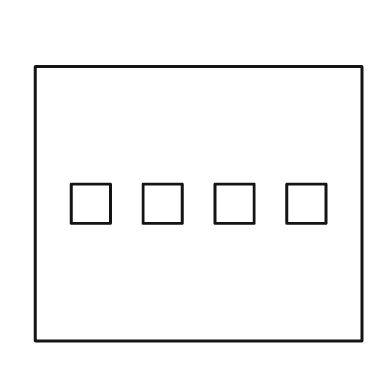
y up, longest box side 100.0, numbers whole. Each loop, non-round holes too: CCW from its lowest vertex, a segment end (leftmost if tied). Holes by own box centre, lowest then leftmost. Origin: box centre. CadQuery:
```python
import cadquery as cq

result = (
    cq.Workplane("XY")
    .moveTo(-50.0, -42.0)
    .lineTo(50.0, -42.0)
    .lineTo(50.0, 42.0)
    .lineTo(-50.0, 42.0)
    .close()
    .moveTo(-39.0, -6.0)
    .lineTo(-27.0, -6.0)
    .lineTo(-27.0, 6.0)
    .lineTo(-39.0, 6.0)
    .close()
    .moveTo(-17.0, -6.0)
    .lineTo(-5.0, -6.0)
    .lineTo(-5.0, 6.0)
    .lineTo(-17.0, 6.0)
    .close()
    .moveTo(5.0, -6.0)
    .lineTo(17.0, -6.0)
    .lineTo(17.0, 6.0)
    .lineTo(5.0, 6.0)
    .close()
    .moveTo(27.0, -6.0)
    .lineTo(39.0, -6.0)
    .lineTo(39.0, 6.0)
    .lineTo(27.0, 6.0)
    .close()
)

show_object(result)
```